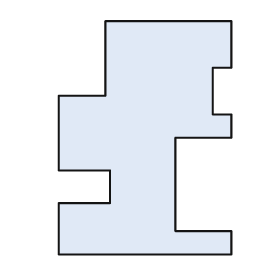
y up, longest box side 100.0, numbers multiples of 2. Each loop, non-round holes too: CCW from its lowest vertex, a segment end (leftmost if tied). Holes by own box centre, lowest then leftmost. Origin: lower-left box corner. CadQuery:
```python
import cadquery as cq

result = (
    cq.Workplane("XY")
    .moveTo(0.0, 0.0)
    .lineTo(74.0, 0.0)
    .lineTo(74.0, 10.0)
    .lineTo(50.0, 10.0)
    .lineTo(50.0, 50.0)
    .lineTo(74.0, 50.0)
    .lineTo(74.0, 60.0)
    .lineTo(66.0, 60.0)
    .lineTo(66.0, 80.0)
    .lineTo(74.0, 80.0)
    .lineTo(74.0, 100.0)
    .lineTo(20.0, 100.0)
    .lineTo(20.0, 68.0)
    .lineTo(0.0, 68.0)
    .lineTo(0.0, 36.0)
    .lineTo(22.0, 36.0)
    .lineTo(22.0, 22.0)
    .lineTo(0.0, 22.0)
    .close()
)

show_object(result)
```